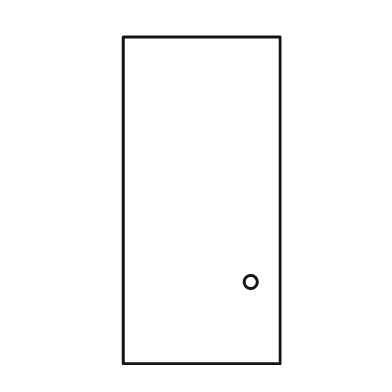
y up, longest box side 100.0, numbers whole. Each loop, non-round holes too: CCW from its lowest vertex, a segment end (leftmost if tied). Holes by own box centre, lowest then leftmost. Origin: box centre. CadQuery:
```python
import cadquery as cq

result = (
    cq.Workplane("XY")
    .moveTo(-24.0, -50.0)
    .lineTo(24.0, -50.0)
    .lineTo(24.0, 50.0)
    .lineTo(-24.0, 50.0)
    .close()
    .moveTo(15.0, -25.0)
    .circle(2.0)
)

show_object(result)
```